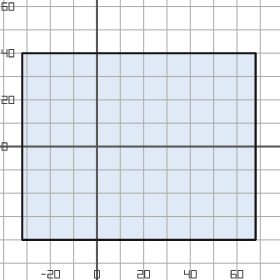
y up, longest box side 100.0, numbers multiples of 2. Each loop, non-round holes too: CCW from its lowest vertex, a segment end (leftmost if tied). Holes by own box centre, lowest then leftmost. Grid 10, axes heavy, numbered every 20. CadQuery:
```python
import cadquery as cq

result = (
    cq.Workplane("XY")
    .moveTo(-32.0, -40.0)
    .lineTo(68.0, -40.0)
    .lineTo(68.0, 40.0)
    .lineTo(-32.0, 40.0)
    .close()
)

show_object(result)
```